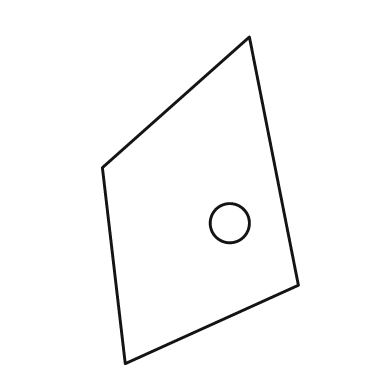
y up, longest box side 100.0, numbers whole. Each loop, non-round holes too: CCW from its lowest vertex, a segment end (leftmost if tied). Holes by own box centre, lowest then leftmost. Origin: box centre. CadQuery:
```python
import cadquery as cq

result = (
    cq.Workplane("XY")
    .moveTo(-23.0, -50.0)
    .lineTo(30.0, -26.0)
    .lineTo(15.0, 50.0)
    .lineTo(-30.0, 10.0)
    .close()
    .moveTo(9.0, -7.0)
    .circle(6.0)
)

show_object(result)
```